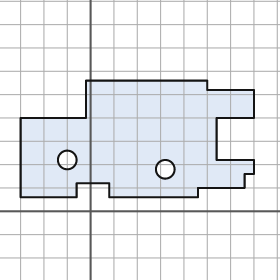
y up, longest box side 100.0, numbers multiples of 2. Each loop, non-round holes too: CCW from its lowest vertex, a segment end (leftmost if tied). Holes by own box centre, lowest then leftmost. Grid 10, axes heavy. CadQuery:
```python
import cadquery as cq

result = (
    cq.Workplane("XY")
    .moveTo(-30.0, 6.0)
    .lineTo(-6.0, 6.0)
    .lineTo(-6.0, 12.0)
    .lineTo(8.0, 12.0)
    .lineTo(8.0, 6.0)
    .lineTo(46.0, 6.0)
    .lineTo(46.0, 10.0)
    .lineTo(66.0, 10.0)
    .lineTo(66.0, 16.0)
    .lineTo(70.0, 16.0)
    .lineTo(70.0, 22.0)
    .lineTo(54.0, 22.0)
    .lineTo(54.0, 40.0)
    .lineTo(70.0, 40.0)
    .lineTo(70.0, 52.0)
    .lineTo(50.0, 52.0)
    .lineTo(50.0, 56.0)
    .lineTo(-2.0, 56.0)
    .lineTo(-2.0, 40.0)
    .lineTo(-30.0, 40.0)
    .close()
    .moveTo(32.0, 18.0)
    .circle(4.0)
    .moveTo(-10.0, 22.0)
    .circle(4.0)
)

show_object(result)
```